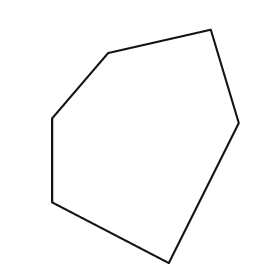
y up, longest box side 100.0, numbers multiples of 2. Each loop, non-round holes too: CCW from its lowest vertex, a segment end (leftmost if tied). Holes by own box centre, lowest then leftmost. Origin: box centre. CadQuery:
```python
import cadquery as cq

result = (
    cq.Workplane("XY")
    .moveTo(10.0, -50.0)
    .lineTo(40.0, 10.0)
    .lineTo(28.0, 50.0)
    .lineTo(-16.0, 40.0)
    .lineTo(-40.0, 12.0)
    .lineTo(-40.0, -24.0)
    .close()
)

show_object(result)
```